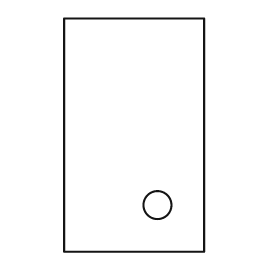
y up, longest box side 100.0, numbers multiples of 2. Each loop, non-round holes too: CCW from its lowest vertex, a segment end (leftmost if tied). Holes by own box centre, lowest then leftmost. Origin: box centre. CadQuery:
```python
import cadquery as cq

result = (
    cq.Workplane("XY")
    .moveTo(-30.0, -50.0)
    .lineTo(30.0, -50.0)
    .lineTo(30.0, 50.0)
    .lineTo(-30.0, 50.0)
    .close()
    .moveTo(10.0, -30.0)
    .circle(6.0)
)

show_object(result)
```